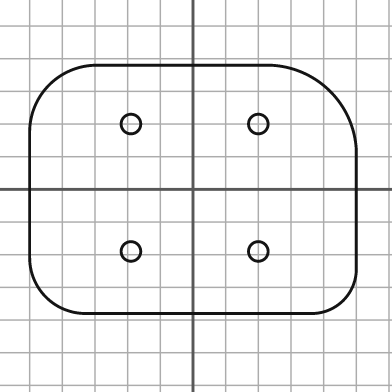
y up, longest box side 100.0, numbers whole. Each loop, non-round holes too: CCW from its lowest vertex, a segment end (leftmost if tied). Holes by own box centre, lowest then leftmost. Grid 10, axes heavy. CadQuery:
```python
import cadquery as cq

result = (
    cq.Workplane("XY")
    .moveTo(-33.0, -38.0)
    .lineTo(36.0, -38.0)
    .threePointArc((46.0, -34.0), (50.0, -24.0))
    .lineTo(50.0, 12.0)
    .threePointArc((42.0, 30.0), (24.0, 38.0))
    .lineTo(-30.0, 38.0)
    .threePointArc((-44.0, 32.0), (-50.0, 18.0))
    .lineTo(-50.0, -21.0)
    .threePointArc((-45.0, -33.0), (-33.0, -38.0))
    .close()
    .moveTo(-19.0, -19.0)
    .circle(3.0)
    .moveTo(20.0, -19.0)
    .circle(3.0)
    .moveTo(-19.0, 20.0)
    .circle(3.0)
    .moveTo(20.0, 20.0)
    .circle(3.0)
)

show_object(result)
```